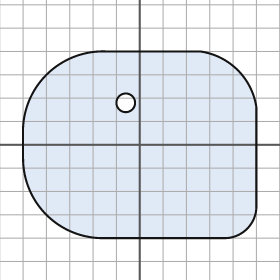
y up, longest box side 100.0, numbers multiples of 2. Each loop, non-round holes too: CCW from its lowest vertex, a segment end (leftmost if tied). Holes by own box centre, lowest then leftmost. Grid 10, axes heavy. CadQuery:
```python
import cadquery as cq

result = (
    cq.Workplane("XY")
    .moveTo(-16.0, -40.0)
    .lineTo(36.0, -40.0)
    .threePointArc((46.0, -36.0), (50.0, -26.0))
    .lineTo(50.0, 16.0)
    .threePointArc((42.0, 32.0), (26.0, 40.0))
    .lineTo(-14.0, 40.0)
    .threePointArc((-40.0, 30.0), (-50.0, 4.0))
    .lineTo(-50.0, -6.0)
    .threePointArc((-40.0, -30.0), (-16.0, -40.0))
    .close()
    .moveTo(-6.0, 18.0)
    .circle(4.0)
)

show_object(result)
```